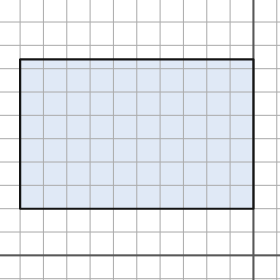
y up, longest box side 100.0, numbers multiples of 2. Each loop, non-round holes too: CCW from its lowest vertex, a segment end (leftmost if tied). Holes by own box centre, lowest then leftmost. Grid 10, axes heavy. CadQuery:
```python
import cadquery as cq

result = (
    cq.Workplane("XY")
    .moveTo(-100.0, 20.0)
    .lineTo(0.0, 20.0)
    .lineTo(0.0, 84.0)
    .lineTo(-100.0, 84.0)
    .close()
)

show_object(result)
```